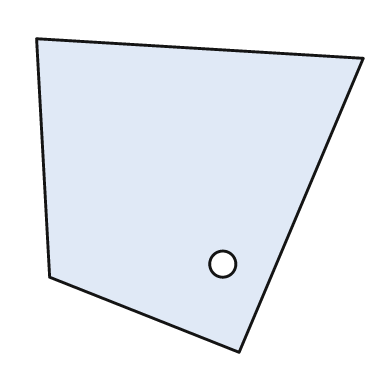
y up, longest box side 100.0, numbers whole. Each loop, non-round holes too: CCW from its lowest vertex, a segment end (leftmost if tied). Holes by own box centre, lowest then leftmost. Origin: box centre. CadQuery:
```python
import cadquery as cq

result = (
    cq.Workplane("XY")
    .moveTo(12.0, -48.0)
    .lineTo(50.0, 42.0)
    .lineTo(-50.0, 48.0)
    .lineTo(-46.0, -25.0)
    .close()
    .moveTo(7.0, -21.0)
    .circle(4.0)
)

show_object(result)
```